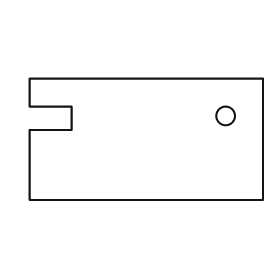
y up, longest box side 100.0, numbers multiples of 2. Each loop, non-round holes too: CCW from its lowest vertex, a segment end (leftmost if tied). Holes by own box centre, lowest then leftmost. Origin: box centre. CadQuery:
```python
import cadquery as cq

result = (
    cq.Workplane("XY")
    .moveTo(-50.0, -26.0)
    .lineTo(50.0, -26.0)
    .lineTo(50.0, 26.0)
    .lineTo(-50.0, 26.0)
    .lineTo(-50.0, 14.0)
    .lineTo(-32.0, 14.0)
    .lineTo(-32.0, 4.0)
    .lineTo(-50.0, 4.0)
    .close()
    .moveTo(34.0, 10.0)
    .circle(4.0)
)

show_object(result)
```